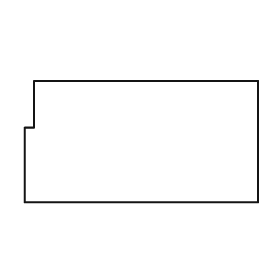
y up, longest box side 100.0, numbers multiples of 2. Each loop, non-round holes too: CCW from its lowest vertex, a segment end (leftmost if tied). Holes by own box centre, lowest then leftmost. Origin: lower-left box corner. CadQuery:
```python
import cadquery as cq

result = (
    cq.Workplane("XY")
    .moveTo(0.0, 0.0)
    .lineTo(100.0, 0.0)
    .lineTo(100.0, 52.0)
    .lineTo(4.0, 52.0)
    .lineTo(4.0, 32.0)
    .lineTo(0.0, 32.0)
    .close()
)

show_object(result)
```